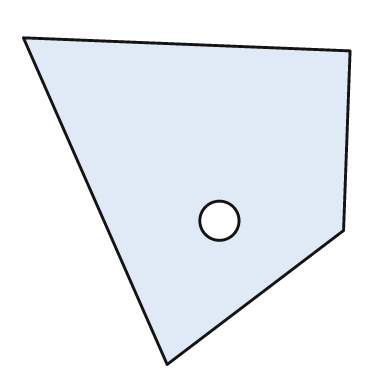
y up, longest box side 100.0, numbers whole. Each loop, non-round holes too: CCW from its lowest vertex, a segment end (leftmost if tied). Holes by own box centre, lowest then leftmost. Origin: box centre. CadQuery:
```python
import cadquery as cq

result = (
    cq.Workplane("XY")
    .moveTo(-6.0, -50.0)
    .lineTo(48.0, -9.0)
    .lineTo(50.0, 46.0)
    .lineTo(-50.0, 50.0)
    .close()
    .moveTo(10.0, -6.0)
    .circle(6.0)
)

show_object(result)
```